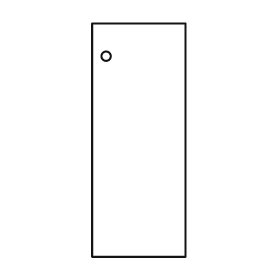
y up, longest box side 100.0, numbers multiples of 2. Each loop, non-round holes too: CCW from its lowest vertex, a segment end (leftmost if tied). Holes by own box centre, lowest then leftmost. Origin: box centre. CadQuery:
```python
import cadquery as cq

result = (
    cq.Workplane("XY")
    .moveTo(-20.0, -50.0)
    .lineTo(20.0, -50.0)
    .lineTo(20.0, 50.0)
    .lineTo(-20.0, 50.0)
    .close()
    .moveTo(-14.0, 36.0)
    .circle(2.0)
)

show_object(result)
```